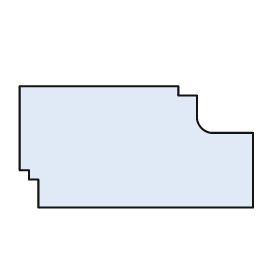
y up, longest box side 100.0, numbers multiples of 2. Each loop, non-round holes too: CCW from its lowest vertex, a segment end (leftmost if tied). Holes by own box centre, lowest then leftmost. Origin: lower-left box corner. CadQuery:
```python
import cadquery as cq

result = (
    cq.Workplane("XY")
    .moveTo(8.0, 0.0)
    .lineTo(100.0, 0.0)
    .lineTo(100.0, 32.0)
    .lineTo(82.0, 32.0)
    .threePointArc((78.0, 34.0), (76.0, 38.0))
    .lineTo(76.0, 48.0)
    .lineTo(68.0, 48.0)
    .lineTo(68.0, 52.0)
    .lineTo(0.0, 52.0)
    .lineTo(0.0, 16.0)
    .lineTo(4.0, 16.0)
    .lineTo(4.0, 12.0)
    .lineTo(8.0, 12.0)
    .close()
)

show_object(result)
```